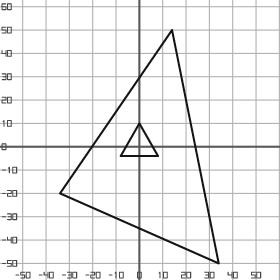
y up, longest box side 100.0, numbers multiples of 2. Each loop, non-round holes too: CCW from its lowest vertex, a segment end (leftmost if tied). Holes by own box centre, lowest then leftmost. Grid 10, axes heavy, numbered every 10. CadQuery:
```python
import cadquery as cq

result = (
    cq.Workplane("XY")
    .moveTo(34.0, -50.0)
    .lineTo(14.0, 50.0)
    .lineTo(-34.0, -20.0)
    .close()
    .moveTo(-8.0, -4.0)
    .lineTo(8.0, -4.0)
    .lineTo(0.0, 10.0)
    .close()
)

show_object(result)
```